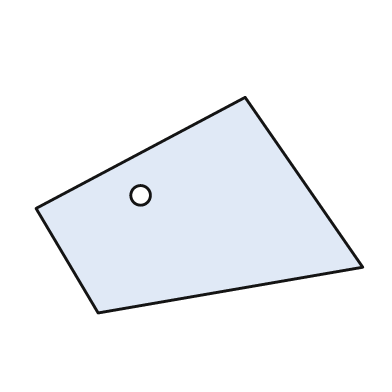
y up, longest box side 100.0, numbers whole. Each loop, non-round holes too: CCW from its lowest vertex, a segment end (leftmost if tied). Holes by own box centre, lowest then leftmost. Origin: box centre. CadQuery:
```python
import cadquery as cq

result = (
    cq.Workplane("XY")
    .moveTo(-31.0, -33.0)
    .lineTo(50.0, -19.0)
    .lineTo(14.0, 33.0)
    .lineTo(-50.0, -1.0)
    .close()
    .moveTo(-18.0, 3.0)
    .circle(3.0)
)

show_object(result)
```